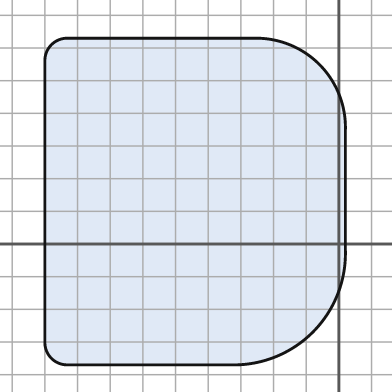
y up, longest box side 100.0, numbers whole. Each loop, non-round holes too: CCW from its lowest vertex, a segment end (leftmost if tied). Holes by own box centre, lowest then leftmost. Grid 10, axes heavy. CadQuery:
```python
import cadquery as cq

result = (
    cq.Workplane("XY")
    .moveTo(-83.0, -37.0)
    .lineTo(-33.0, -37.0)
    .threePointArc((-8.0, -27.0), (2.0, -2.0))
    .lineTo(2.0, 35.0)
    .threePointArc((-6.0, 55.0), (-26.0, 63.0))
    .lineTo(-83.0, 63.0)
    .threePointArc((-88.0, 61.0), (-90.0, 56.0))
    .lineTo(-90.0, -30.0)
    .threePointArc((-88.0, -35.0), (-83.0, -37.0))
    .close()
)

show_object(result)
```